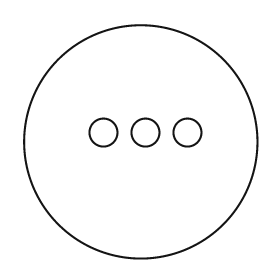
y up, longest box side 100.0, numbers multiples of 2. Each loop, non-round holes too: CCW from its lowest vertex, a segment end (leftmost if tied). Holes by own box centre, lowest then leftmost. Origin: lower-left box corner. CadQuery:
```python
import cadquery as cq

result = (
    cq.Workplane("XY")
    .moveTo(50.0, 50.0)
    .circle(50.0)
    .moveTo(34.0, 54.0)
    .circle(6.0)
    .moveTo(52.0, 54.0)
    .circle(6.0)
    .moveTo(70.0, 54.0)
    .circle(6.0)
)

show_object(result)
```